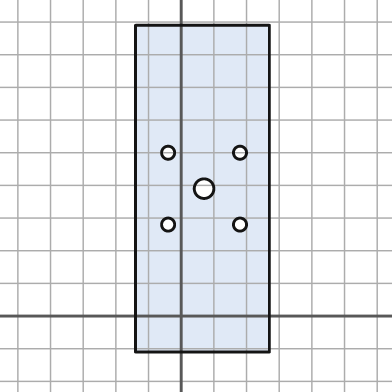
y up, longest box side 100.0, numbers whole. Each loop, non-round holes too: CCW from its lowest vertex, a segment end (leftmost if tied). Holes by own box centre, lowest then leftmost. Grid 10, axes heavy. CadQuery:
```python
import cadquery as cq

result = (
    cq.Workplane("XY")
    .moveTo(-14.0, -11.0)
    .lineTo(27.0, -11.0)
    .lineTo(27.0, 89.0)
    .lineTo(-14.0, 89.0)
    .close()
    .moveTo(-4.0, 28.0)
    .circle(2.0)
    .moveTo(18.0, 28.0)
    .circle(2.0)
    .moveTo(7.0, 39.0)
    .circle(3.0)
    .moveTo(-4.0, 50.0)
    .circle(2.0)
    .moveTo(18.0, 50.0)
    .circle(2.0)
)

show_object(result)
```